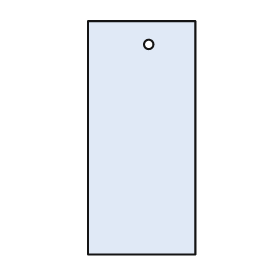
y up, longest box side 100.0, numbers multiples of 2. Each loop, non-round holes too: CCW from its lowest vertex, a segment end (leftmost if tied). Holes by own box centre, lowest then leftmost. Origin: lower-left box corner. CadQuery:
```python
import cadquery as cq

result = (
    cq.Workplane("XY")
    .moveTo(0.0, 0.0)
    .lineTo(46.0, 0.0)
    .lineTo(46.0, 100.0)
    .lineTo(0.0, 100.0)
    .close()
    .moveTo(26.0, 90.0)
    .circle(2.0)
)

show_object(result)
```